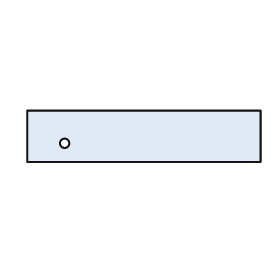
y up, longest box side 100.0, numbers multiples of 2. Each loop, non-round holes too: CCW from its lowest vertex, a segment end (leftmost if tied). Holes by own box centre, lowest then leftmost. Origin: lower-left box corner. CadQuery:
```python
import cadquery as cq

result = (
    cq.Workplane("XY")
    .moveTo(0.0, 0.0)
    .lineTo(100.0, 0.0)
    .lineTo(100.0, 22.0)
    .lineTo(0.0, 22.0)
    .close()
    .moveTo(16.0, 8.0)
    .circle(2.0)
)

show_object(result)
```